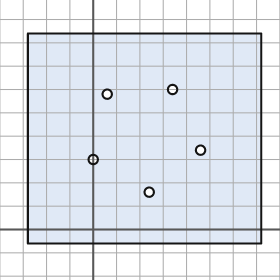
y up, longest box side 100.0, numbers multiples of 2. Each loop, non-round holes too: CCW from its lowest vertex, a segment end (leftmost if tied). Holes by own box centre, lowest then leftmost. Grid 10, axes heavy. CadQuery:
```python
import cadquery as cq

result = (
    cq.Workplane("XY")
    .moveTo(-28.0, -6.0)
    .lineTo(72.0, -6.0)
    .lineTo(72.0, 84.0)
    .lineTo(-28.0, 84.0)
    .close()
    .moveTo(24.0, 16.0)
    .circle(2.0)
    .moveTo(0.0, 30.0)
    .circle(2.0)
    .moveTo(46.0, 34.0)
    .circle(2.0)
    .moveTo(6.0, 58.0)
    .circle(2.0)
    .moveTo(34.0, 60.0)
    .circle(2.0)
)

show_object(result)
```